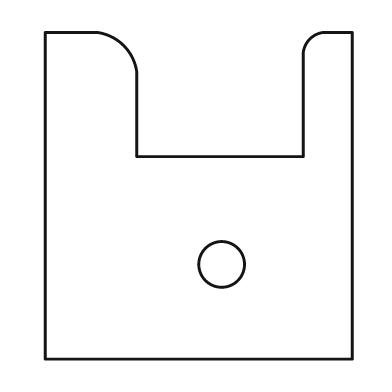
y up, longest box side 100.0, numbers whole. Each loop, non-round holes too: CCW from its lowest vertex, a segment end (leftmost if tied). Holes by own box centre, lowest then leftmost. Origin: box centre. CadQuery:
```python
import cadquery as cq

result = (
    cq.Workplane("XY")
    .moveTo(-47.0, -50.0)
    .lineTo(47.0, -50.0)
    .lineTo(47.0, 50.0)
    .lineTo(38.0, 50.0)
    .threePointArc((34.0, 48.0), (32.0, 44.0))
    .lineTo(32.0, 12.0)
    .lineTo(-19.0, 12.0)
    .lineTo(-19.0, 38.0)
    .threePointArc((-23.0, 46.0), (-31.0, 50.0))
    .lineTo(-47.0, 50.0)
    .close()
    .moveTo(7.0, -21.0)
    .circle(7.0)
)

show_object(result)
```